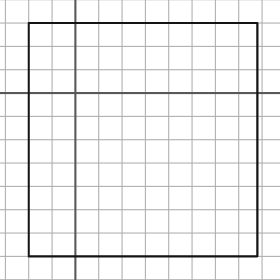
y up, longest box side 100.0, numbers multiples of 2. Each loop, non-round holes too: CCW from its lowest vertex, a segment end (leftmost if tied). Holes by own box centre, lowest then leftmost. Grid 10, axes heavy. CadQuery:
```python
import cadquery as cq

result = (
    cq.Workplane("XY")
    .moveTo(-20.0, -70.0)
    .lineTo(78.0, -70.0)
    .lineTo(78.0, 30.0)
    .lineTo(-20.0, 30.0)
    .close()
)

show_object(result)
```